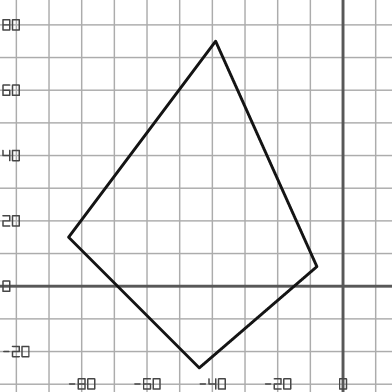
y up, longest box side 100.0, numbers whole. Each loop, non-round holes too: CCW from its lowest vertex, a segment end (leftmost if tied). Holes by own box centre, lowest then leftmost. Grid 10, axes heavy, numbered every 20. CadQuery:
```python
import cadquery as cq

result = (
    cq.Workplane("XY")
    .moveTo(-44.0, -25.0)
    .lineTo(-8.0, 6.0)
    .lineTo(-39.0, 75.0)
    .lineTo(-84.0, 15.0)
    .close()
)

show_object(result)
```